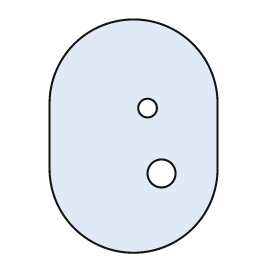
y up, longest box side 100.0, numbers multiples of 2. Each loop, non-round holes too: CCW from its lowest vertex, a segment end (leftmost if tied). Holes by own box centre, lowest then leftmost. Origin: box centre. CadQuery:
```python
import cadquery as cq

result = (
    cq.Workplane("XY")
    .moveTo(-36.0, -14.0)
    .threePointArc((0.0, -50.0), (36.0, -14.0))
    .lineTo(36.0, 14.0)
    .threePointArc((0.0, 50.0), (-36.0, 14.0))
    .close()
    .moveTo(12.0, -16.0)
    .circle(6.0)
    .moveTo(6.0, 12.0)
    .circle(4.0)
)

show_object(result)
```